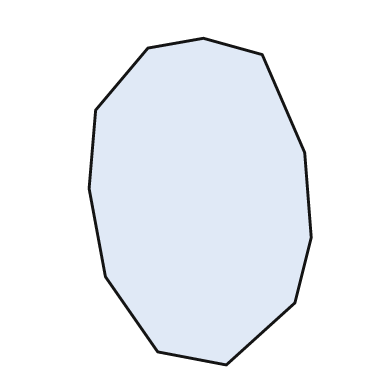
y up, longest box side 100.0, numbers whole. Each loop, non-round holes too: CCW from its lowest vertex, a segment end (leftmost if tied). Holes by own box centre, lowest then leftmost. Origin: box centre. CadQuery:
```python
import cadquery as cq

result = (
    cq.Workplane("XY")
    .moveTo(8.0, -50.0)
    .lineTo(29.0, -31.0)
    .lineTo(34.0, -11.0)
    .lineTo(32.0, 15.0)
    .lineTo(19.0, 45.0)
    .lineTo(1.0, 50.0)
    .lineTo(-16.0, 47.0)
    .lineTo(-32.0, 28.0)
    .lineTo(-34.0, 4.0)
    .lineTo(-29.0, -23.0)
    .lineTo(-13.0, -46.0)
    .close()
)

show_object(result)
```